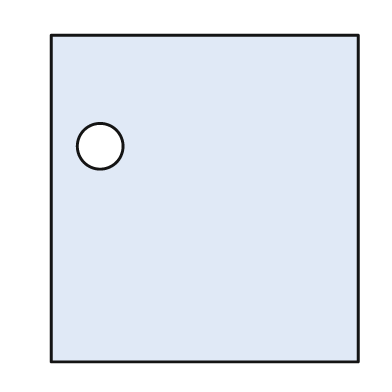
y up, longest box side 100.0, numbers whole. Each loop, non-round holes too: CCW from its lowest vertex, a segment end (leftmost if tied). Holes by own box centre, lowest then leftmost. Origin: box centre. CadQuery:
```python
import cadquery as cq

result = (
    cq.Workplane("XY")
    .moveTo(-47.0, -50.0)
    .lineTo(47.0, -50.0)
    .lineTo(47.0, 50.0)
    .lineTo(-47.0, 50.0)
    .close()
    .moveTo(-32.0, 16.0)
    .circle(7.0)
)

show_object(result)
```